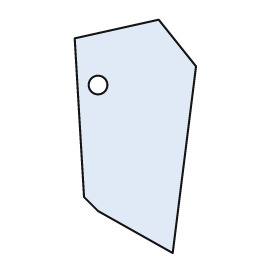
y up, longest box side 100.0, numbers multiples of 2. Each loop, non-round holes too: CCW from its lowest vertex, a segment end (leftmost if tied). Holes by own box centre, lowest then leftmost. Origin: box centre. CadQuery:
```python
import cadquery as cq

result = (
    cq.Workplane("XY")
    .moveTo(16.0, -50.0)
    .lineTo(26.0, 30.0)
    .lineTo(10.0, 50.0)
    .lineTo(-26.0, 42.0)
    .lineTo(-22.0, -26.0)
    .lineTo(-16.0, -32.0)
    .close()
    .moveTo(-16.0, 22.0)
    .circle(4.0)
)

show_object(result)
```